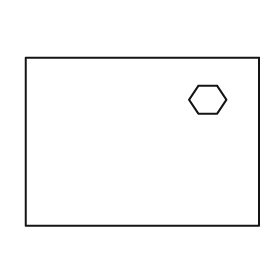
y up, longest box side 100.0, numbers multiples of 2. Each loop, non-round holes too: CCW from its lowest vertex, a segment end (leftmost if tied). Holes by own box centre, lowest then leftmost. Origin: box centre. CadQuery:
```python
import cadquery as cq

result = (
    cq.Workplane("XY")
    .moveTo(-50.0, -36.0)
    .lineTo(50.0, -36.0)
    .lineTo(50.0, 36.0)
    .lineTo(-50.0, 36.0)
    .close()
    .moveTo(24.0, 12.0)
    .lineTo(32.0, 12.0)
    .lineTo(36.0, 18.0)
    .lineTo(32.0, 24.0)
    .lineTo(24.0, 24.0)
    .lineTo(20.0, 18.0)
    .close()
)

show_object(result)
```